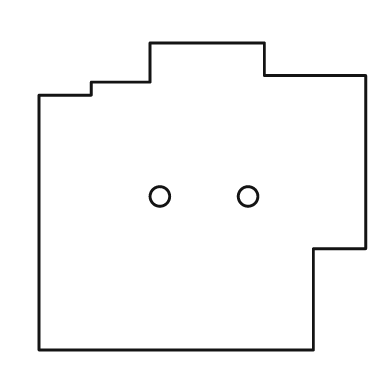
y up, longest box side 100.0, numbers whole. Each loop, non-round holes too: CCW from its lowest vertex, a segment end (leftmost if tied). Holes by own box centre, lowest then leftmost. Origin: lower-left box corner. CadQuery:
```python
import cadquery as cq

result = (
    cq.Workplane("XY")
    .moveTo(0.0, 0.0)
    .lineTo(84.0, 0.0)
    .lineTo(84.0, 31.0)
    .lineTo(100.0, 31.0)
    .lineTo(100.0, 84.0)
    .lineTo(69.0, 84.0)
    .lineTo(69.0, 94.0)
    .lineTo(34.0, 94.0)
    .lineTo(34.0, 82.0)
    .lineTo(16.0, 82.0)
    .lineTo(16.0, 78.0)
    .lineTo(0.0, 78.0)
    .close()
    .moveTo(37.0, 47.0)
    .circle(3.0)
    .moveTo(64.0, 47.0)
    .circle(3.0)
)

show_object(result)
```